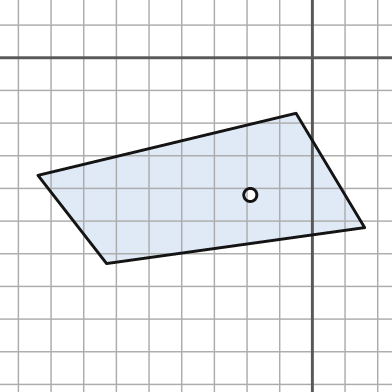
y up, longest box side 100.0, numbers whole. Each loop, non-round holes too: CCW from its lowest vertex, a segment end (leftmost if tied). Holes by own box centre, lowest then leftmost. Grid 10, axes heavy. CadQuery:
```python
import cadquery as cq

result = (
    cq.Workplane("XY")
    .moveTo(-63.0, -63.0)
    .lineTo(16.0, -52.0)
    .lineTo(-5.0, -17.0)
    .lineTo(-84.0, -36.0)
    .close()
    .moveTo(-19.0, -42.0)
    .circle(2.0)
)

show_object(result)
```